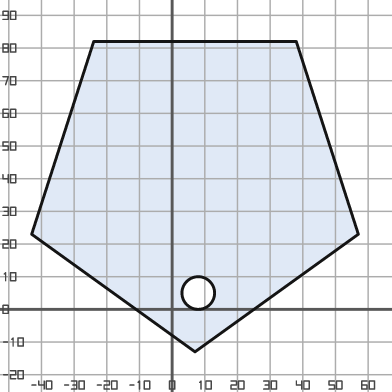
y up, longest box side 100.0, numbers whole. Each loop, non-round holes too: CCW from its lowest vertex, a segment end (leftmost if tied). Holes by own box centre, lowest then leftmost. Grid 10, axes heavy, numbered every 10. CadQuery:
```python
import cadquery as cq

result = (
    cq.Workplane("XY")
    .moveTo(7.0, -13.0)
    .lineTo(57.0, 23.0)
    .lineTo(38.0, 82.0)
    .lineTo(-24.0, 82.0)
    .lineTo(-43.0, 23.0)
    .close()
    .moveTo(8.0, 5.0)
    .circle(5.0)
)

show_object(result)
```